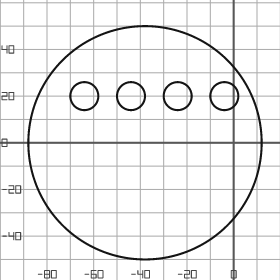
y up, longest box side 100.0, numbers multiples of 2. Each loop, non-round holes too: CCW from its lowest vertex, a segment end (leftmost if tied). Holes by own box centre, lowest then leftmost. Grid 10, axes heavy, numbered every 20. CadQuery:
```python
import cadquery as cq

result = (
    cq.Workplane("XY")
    .moveTo(-38.0, 0.0)
    .circle(50.0)
    .moveTo(-64.0, 20.0)
    .circle(6.0)
    .moveTo(-44.0, 20.0)
    .circle(6.0)
    .moveTo(-24.0, 20.0)
    .circle(6.0)
    .moveTo(-4.0, 20.0)
    .circle(6.0)
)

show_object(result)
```